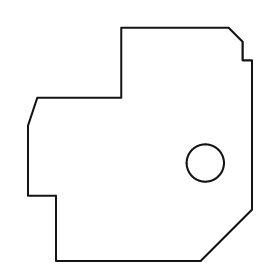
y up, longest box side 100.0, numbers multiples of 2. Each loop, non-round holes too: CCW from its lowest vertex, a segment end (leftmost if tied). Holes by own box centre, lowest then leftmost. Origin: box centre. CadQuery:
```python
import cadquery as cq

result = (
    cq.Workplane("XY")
    .moveTo(-36.0, -50.0)
    .lineTo(26.0, -50.0)
    .lineTo(48.0, -28.0)
    .lineTo(48.0, 36.0)
    .lineTo(44.0, 36.0)
    .lineTo(44.0, 44.0)
    .lineTo(38.0, 50.0)
    .lineTo(-8.0, 50.0)
    .lineTo(-8.0, 20.0)
    .lineTo(-44.0, 20.0)
    .lineTo(-48.0, 8.0)
    .lineTo(-48.0, -22.0)
    .lineTo(-36.0, -22.0)
    .close()
    .moveTo(28.0, -8.0)
    .circle(8.0)
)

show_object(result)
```